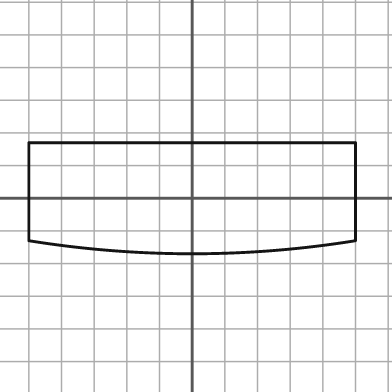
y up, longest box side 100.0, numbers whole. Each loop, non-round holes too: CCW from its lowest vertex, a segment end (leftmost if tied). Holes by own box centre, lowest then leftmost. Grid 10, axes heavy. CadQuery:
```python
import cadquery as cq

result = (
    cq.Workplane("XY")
    .moveTo(-50.0, -13.0)
    .threePointArc((0.0, -17.0), (50.0, -13.0))
    .lineTo(50.0, 17.0)
    .lineTo(-50.0, 17.0)
    .close()
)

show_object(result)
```